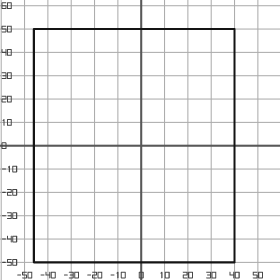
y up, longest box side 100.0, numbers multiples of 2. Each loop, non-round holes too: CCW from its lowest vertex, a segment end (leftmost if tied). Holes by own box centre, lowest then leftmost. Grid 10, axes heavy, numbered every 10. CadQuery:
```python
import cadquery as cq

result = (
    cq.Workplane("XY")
    .moveTo(-46.0, -50.0)
    .lineTo(40.0, -50.0)
    .lineTo(40.0, 50.0)
    .lineTo(-46.0, 50.0)
    .close()
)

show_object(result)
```